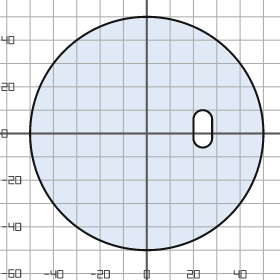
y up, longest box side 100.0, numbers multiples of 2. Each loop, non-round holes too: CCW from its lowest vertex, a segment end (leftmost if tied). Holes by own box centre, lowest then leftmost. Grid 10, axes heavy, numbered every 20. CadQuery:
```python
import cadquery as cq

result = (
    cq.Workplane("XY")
    .moveTo(0.0, 0.0)
    .circle(50.0)
    .moveTo(20.0, -2.0)
    .threePointArc((24.0, -6.0), (28.0, -2.0))
    .lineTo(28.0, 6.0)
    .threePointArc((24.0, 10.0), (20.0, 6.0))
    .close()
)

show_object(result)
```